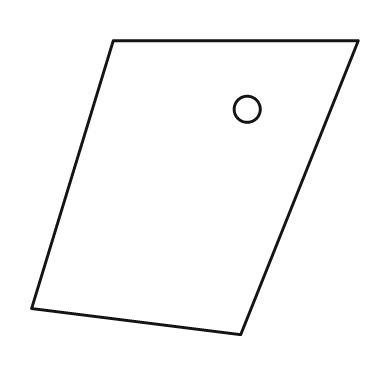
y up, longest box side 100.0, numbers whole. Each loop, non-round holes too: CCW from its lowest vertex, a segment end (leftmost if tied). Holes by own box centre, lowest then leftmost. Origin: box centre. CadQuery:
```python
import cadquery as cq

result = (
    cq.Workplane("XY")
    .moveTo(14.0, -45.0)
    .lineTo(50.0, 45.0)
    .lineTo(-25.0, 45.0)
    .lineTo(-50.0, -37.0)
    .close()
    .moveTo(16.0, 24.0)
    .circle(4.0)
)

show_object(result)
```